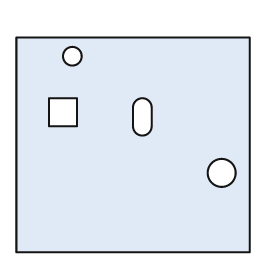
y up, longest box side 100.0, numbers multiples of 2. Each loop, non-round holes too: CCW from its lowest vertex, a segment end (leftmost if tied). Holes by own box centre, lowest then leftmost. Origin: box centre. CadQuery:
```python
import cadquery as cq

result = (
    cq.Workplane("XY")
    .moveTo(-50.0, -46.0)
    .lineTo(50.0, -46.0)
    .lineTo(50.0, 46.0)
    .lineTo(-50.0, 46.0)
    .close()
    .moveTo(38.0, -12.0)
    .circle(6.0)
    .moveTo(0.0, 8.0)
    .threePointArc((4.0, 4.0), (8.0, 8.0))
    .lineTo(8.0, 16.0)
    .threePointArc((4.0, 20.0), (0.0, 16.0))
    .close()
    .moveTo(-36.0, 8.0)
    .lineTo(-24.0, 8.0)
    .lineTo(-24.0, 20.0)
    .lineTo(-36.0, 20.0)
    .close()
    .moveTo(-26.0, 38.0)
    .circle(4.0)
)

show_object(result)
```